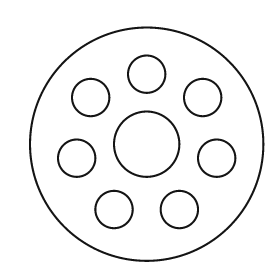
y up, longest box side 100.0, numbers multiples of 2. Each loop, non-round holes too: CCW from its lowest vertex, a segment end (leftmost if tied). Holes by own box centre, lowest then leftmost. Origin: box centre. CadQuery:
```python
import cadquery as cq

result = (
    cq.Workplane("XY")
    .moveTo(0.0, 0.0)
    .circle(50.0)
    .moveTo(-14.0, -28.0)
    .circle(8.0)
    .moveTo(14.0, -28.0)
    .circle(8.0)
    .moveTo(-30.0, -6.0)
    .circle(8.0)
    .moveTo(30.0, -6.0)
    .circle(8.0)
    .moveTo(0.0, 0.0)
    .circle(14.0)
    .moveTo(-24.0, 20.0)
    .circle(8.0)
    .moveTo(24.0, 20.0)
    .circle(8.0)
    .moveTo(0.0, 30.0)
    .circle(8.0)
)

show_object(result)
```